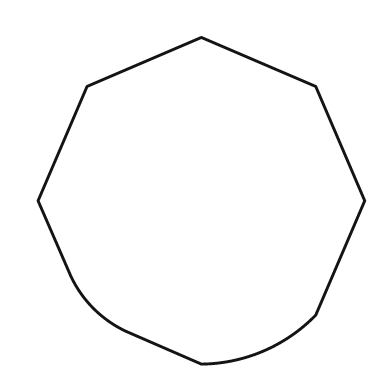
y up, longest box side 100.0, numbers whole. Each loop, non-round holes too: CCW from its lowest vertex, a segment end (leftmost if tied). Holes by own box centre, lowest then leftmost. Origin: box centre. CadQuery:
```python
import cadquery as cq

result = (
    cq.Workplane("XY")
    .moveTo(0.0, -50.0)
    .threePointArc((19.0, -46.0), (35.0, -35.0))
    .lineTo(50.0, 0.0)
    .lineTo(35.0, 35.0)
    .lineTo(0.0, 50.0)
    .lineTo(-35.0, 35.0)
    .lineTo(-50.0, 0.0)
    .lineTo(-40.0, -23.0)
    .threePointArc((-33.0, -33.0), (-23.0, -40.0))
    .close()
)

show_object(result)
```